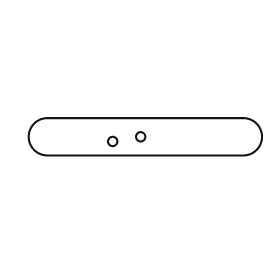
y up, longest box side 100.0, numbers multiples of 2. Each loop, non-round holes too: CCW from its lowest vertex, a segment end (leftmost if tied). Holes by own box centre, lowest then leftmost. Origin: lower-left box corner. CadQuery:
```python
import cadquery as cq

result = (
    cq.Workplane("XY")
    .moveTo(8.0, 0.0)
    .lineTo(92.0, 0.0)
    .threePointArc((100.0, 8.0), (92.0, 16.0))
    .lineTo(8.0, 16.0)
    .threePointArc((0.0, 8.0), (8.0, 0.0))
    .close()
    .moveTo(36.0, 6.0)
    .circle(2.0)
    .moveTo(48.0, 8.0)
    .circle(2.0)
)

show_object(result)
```